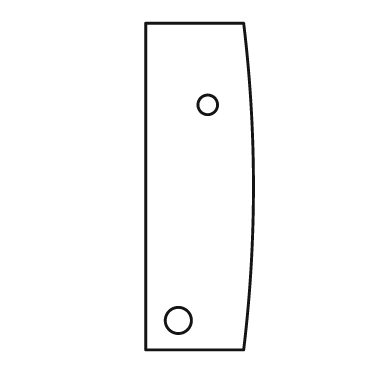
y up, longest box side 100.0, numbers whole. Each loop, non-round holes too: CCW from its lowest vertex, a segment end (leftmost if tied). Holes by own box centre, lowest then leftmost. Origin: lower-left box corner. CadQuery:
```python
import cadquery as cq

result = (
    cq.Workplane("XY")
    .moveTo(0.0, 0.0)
    .lineTo(30.0, 0.0)
    .threePointArc((33.0, 50.0), (30.0, 100.0))
    .lineTo(0.0, 100.0)
    .close()
    .moveTo(10.0, 9.0)
    .circle(4.0)
    .moveTo(19.0, 75.0)
    .circle(3.0)
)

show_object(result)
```